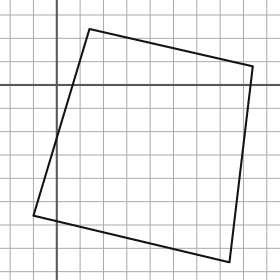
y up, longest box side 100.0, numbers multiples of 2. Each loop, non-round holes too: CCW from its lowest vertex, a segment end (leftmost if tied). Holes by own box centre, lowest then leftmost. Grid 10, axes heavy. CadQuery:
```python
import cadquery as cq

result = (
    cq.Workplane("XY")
    .moveTo(74.0, -76.0)
    .lineTo(84.0, 8.0)
    .lineTo(14.0, 24.0)
    .lineTo(-10.0, -56.0)
    .close()
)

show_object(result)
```